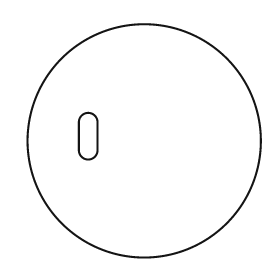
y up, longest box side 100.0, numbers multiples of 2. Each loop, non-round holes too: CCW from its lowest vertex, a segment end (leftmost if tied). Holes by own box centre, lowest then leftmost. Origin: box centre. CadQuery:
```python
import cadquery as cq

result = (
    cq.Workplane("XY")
    .moveTo(0.0, 0.0)
    .circle(50.0)
    .moveTo(-28.0, -4.0)
    .threePointArc((-24.0, -8.0), (-20.0, -4.0))
    .lineTo(-20.0, 8.0)
    .threePointArc((-24.0, 12.0), (-28.0, 8.0))
    .close()
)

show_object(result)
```